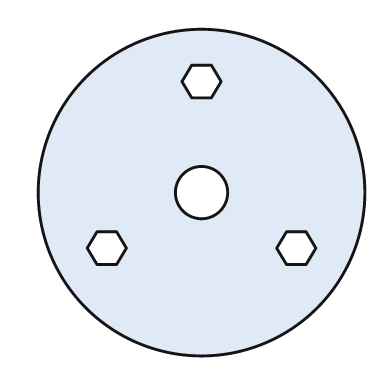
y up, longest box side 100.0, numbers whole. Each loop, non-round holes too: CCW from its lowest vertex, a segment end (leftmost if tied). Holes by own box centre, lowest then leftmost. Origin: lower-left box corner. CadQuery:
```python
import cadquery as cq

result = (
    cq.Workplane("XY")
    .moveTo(50.0, 50.0)
    .circle(50.0)
    .moveTo(18.0, 28.0)
    .lineTo(24.0, 28.0)
    .lineTo(27.0, 33.0)
    .lineTo(24.0, 38.0)
    .lineTo(18.0, 38.0)
    .lineTo(15.0, 33.0)
    .close()
    .moveTo(76.0, 28.0)
    .lineTo(82.0, 28.0)
    .lineTo(85.0, 33.0)
    .lineTo(82.0, 38.0)
    .lineTo(76.0, 38.0)
    .lineTo(73.0, 33.0)
    .close()
    .moveTo(50.0, 50.0)
    .circle(8.0)
    .moveTo(47.0, 79.0)
    .lineTo(53.0, 79.0)
    .lineTo(56.0, 84.0)
    .lineTo(53.0, 89.0)
    .lineTo(47.0, 89.0)
    .lineTo(44.0, 84.0)
    .close()
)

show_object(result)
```